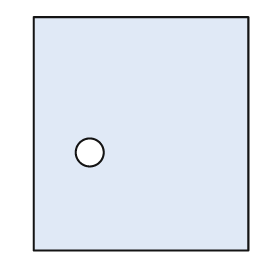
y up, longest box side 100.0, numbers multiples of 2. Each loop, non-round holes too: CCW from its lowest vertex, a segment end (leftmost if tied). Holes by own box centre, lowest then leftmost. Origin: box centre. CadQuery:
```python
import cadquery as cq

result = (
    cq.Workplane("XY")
    .moveTo(-46.0, -50.0)
    .lineTo(46.0, -50.0)
    .lineTo(46.0, 50.0)
    .lineTo(-46.0, 50.0)
    .close()
    .moveTo(-22.0, -8.0)
    .circle(6.0)
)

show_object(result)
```